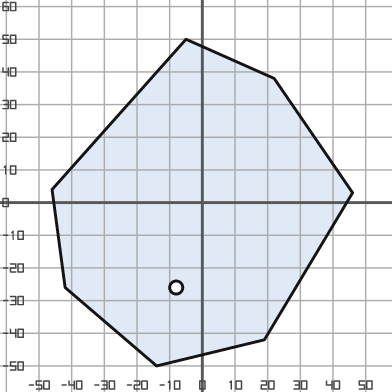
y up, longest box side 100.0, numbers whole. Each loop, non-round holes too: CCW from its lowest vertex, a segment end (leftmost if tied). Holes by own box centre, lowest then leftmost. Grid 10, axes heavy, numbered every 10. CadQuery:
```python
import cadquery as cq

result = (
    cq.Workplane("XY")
    .moveTo(-14.0, -50.0)
    .lineTo(19.0, -42.0)
    .lineTo(46.0, 3.0)
    .lineTo(22.0, 38.0)
    .lineTo(-5.0, 50.0)
    .lineTo(-46.0, 4.0)
    .lineTo(-42.0, -26.0)
    .close()
    .moveTo(-8.0, -26.0)
    .circle(2.0)
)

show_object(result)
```